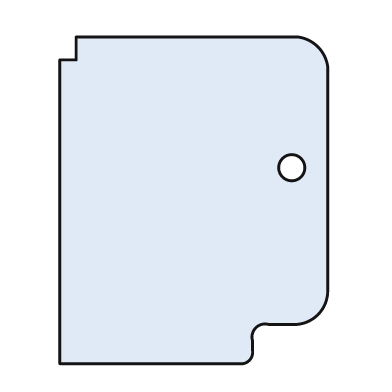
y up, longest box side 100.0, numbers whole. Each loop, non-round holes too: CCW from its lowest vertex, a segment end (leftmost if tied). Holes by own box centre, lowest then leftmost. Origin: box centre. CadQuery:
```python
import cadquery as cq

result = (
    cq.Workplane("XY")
    .moveTo(-41.0, -50.0)
    .lineTo(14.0, -50.0)
    .threePointArc((17.0, -49.0), (18.0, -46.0))
    .lineTo(18.0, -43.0)
    .threePointArc((19.0, -39.0), (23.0, -38.0))
    .lineTo(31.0, -38.0)
    .threePointArc((38.0, -35.0), (41.0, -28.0))
    .lineTo(41.0, 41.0)
    .threePointArc((38.0, 47.0), (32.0, 50.0))
    .lineTo(-36.0, 50.0)
    .lineTo(-36.0, 43.0)
    .lineTo(-41.0, 43.0)
    .close()
    .moveTo(30.0, 10.0)
    .circle(4.0)
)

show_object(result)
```